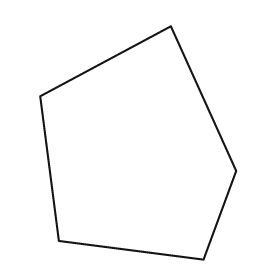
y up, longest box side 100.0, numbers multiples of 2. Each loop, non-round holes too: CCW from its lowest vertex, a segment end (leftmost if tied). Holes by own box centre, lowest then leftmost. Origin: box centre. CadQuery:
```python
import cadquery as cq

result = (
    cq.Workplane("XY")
    .moveTo(28.0, -50.0)
    .lineTo(42.0, -12.0)
    .lineTo(14.0, 50.0)
    .lineTo(-42.0, 20.0)
    .lineTo(-34.0, -42.0)
    .close()
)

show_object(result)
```